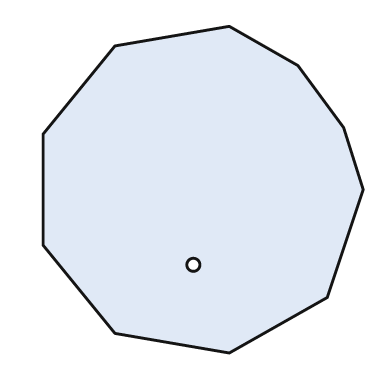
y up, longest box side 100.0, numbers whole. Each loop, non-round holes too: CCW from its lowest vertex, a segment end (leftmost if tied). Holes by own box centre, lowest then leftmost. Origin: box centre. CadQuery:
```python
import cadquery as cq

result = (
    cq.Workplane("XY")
    .moveTo(8.0, -50.0)
    .lineTo(38.0, -33.0)
    .lineTo(49.0, 0.0)
    .lineTo(43.0, 19.0)
    .lineTo(29.0, 38.0)
    .lineTo(8.0, 50.0)
    .lineTo(-27.0, 44.0)
    .lineTo(-49.0, 17.0)
    .lineTo(-49.0, -17.0)
    .lineTo(-27.0, -44.0)
    .close()
    .moveTo(-3.0, -23.0)
    .circle(2.0)
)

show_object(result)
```